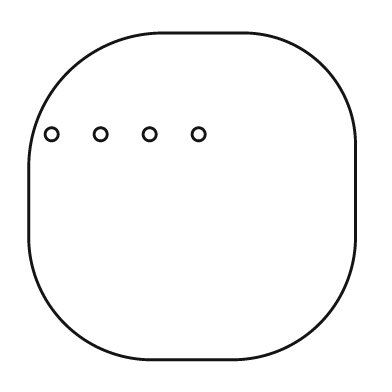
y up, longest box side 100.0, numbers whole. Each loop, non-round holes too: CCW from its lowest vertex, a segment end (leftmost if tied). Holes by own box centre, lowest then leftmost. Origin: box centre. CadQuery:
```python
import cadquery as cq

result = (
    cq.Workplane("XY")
    .moveTo(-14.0, -50.0)
    .lineTo(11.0, -50.0)
    .threePointArc((39.0, -39.0), (50.0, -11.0))
    .lineTo(50.0, 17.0)
    .threePointArc((40.0, 40.0), (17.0, 50.0))
    .lineTo(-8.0, 50.0)
    .threePointArc((-38.0, 38.0), (-50.0, 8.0))
    .lineTo(-50.0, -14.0)
    .threePointArc((-39.0, -39.0), (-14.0, -50.0))
    .close()
    .moveTo(-43.0, 19.0)
    .circle(2.0)
    .moveTo(-28.0, 19.0)
    .circle(2.0)
    .moveTo(-13.0, 19.0)
    .circle(2.0)
    .moveTo(2.0, 19.0)
    .circle(2.0)
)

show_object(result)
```